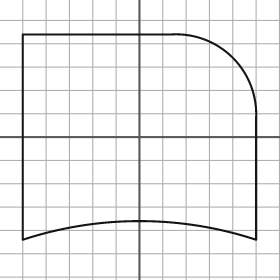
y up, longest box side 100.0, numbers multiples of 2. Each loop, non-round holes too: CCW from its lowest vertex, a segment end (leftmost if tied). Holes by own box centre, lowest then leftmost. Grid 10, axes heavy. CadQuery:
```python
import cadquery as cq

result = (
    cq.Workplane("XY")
    .moveTo(-50.0, -44.0)
    .threePointArc((0.0, -36.0), (50.0, -44.0))
    .lineTo(50.0, 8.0)
    .threePointArc((40.0, 34.0), (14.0, 44.0))
    .lineTo(-50.0, 44.0)
    .close()
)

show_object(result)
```